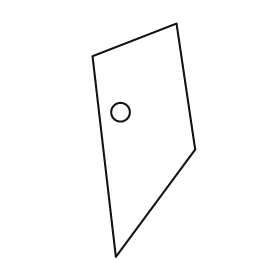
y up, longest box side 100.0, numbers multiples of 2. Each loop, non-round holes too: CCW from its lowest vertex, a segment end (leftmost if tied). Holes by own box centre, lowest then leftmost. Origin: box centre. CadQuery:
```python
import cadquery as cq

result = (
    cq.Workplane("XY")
    .moveTo(-12.0, -50.0)
    .lineTo(22.0, -4.0)
    .lineTo(14.0, 50.0)
    .lineTo(-22.0, 36.0)
    .close()
    .moveTo(-10.0, 12.0)
    .circle(4.0)
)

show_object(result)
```